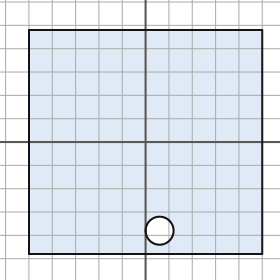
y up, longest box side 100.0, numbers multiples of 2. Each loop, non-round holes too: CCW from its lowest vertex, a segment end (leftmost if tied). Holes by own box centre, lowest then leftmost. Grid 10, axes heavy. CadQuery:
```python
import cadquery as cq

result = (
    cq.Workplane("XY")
    .moveTo(-50.0, -48.0)
    .lineTo(50.0, -48.0)
    .lineTo(50.0, 48.0)
    .lineTo(-50.0, 48.0)
    .close()
    .moveTo(6.0, -38.0)
    .circle(6.0)
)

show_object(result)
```